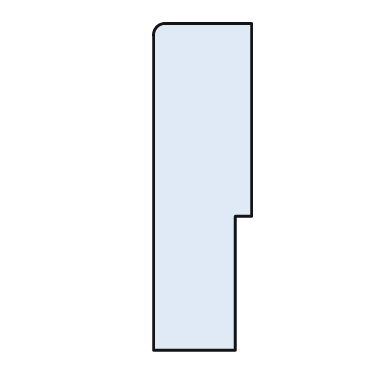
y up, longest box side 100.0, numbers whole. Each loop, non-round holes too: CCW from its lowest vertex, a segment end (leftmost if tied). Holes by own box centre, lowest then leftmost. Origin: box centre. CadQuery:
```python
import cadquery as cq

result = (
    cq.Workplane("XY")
    .moveTo(-15.0, -50.0)
    .lineTo(10.0, -50.0)
    .lineTo(10.0, -9.0)
    .lineTo(15.0, -9.0)
    .lineTo(15.0, 50.0)
    .lineTo(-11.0, 50.0)
    .threePointArc((-14.0, 49.0), (-15.0, 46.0))
    .close()
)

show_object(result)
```